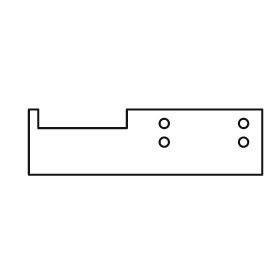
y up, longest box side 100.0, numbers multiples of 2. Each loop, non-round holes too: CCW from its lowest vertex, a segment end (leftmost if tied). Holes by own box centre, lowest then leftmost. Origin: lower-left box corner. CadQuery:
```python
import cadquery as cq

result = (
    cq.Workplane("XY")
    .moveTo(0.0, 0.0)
    .lineTo(100.0, 0.0)
    .lineTo(100.0, 28.0)
    .lineTo(42.0, 28.0)
    .lineTo(42.0, 20.0)
    .lineTo(4.0, 20.0)
    .lineTo(4.0, 28.0)
    .lineTo(0.0, 28.0)
    .close()
    .moveTo(58.0, 14.0)
    .circle(2.0)
    .moveTo(92.0, 14.0)
    .circle(2.0)
    .moveTo(58.0, 22.0)
    .circle(2.0)
    .moveTo(92.0, 22.0)
    .circle(2.0)
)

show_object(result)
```